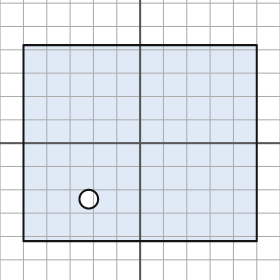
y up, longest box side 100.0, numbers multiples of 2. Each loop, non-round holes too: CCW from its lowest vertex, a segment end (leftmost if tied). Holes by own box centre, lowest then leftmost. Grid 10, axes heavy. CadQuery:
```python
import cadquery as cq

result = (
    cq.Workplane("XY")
    .moveTo(-50.0, -42.0)
    .lineTo(50.0, -42.0)
    .lineTo(50.0, 42.0)
    .lineTo(-50.0, 42.0)
    .close()
    .moveTo(-22.0, -24.0)
    .circle(4.0)
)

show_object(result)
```